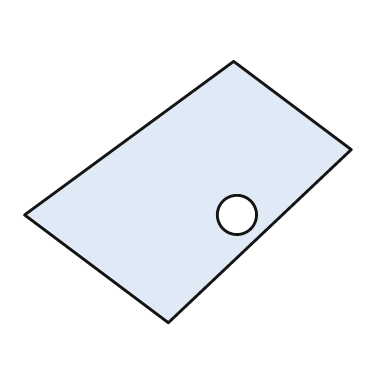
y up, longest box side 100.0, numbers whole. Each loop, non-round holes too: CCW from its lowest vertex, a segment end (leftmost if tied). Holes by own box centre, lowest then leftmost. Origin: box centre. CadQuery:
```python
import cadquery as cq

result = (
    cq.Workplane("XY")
    .moveTo(-6.0, -40.0)
    .lineTo(50.0, 13.0)
    .lineTo(14.0, 40.0)
    .lineTo(-50.0, -7.0)
    .close()
    .moveTo(15.0, -7.0)
    .circle(6.0)
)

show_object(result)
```